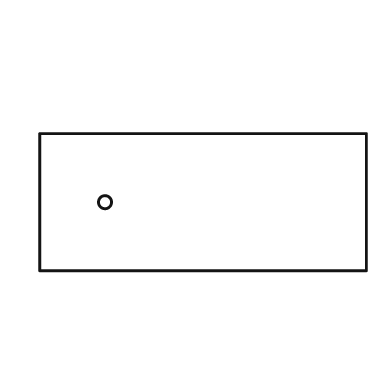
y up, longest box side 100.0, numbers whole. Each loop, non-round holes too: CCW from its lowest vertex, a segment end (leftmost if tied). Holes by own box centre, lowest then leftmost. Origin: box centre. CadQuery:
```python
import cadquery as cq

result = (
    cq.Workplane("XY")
    .moveTo(-50.0, -21.0)
    .lineTo(50.0, -21.0)
    .lineTo(50.0, 21.0)
    .lineTo(-50.0, 21.0)
    .close()
    .moveTo(-30.0, 0.0)
    .circle(2.0)
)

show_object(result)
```